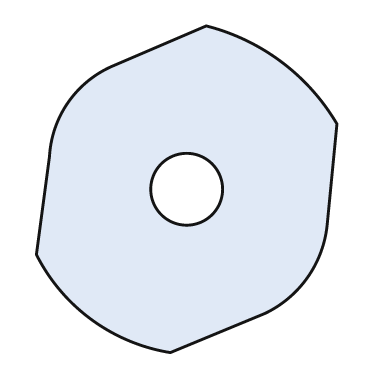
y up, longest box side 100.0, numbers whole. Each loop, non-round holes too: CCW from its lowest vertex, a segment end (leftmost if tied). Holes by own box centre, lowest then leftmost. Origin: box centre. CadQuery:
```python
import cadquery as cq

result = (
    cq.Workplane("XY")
    .moveTo(-5.0, -50.0)
    .lineTo(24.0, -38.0)
    .threePointArc((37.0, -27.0), (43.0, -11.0))
    .lineTo(46.0, 20.0)
    .threePointArc((29.0, 39.0), (6.0, 50.0))
    .lineTo(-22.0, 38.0)
    .threePointArc((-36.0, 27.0), (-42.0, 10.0))
    .lineTo(-46.0, -20.0)
    .threePointArc((-29.0, -40.0), (-5.0, -50.0))
    .close()
    .moveTo(0.0, 0.0)
    .circle(11.0)
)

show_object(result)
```